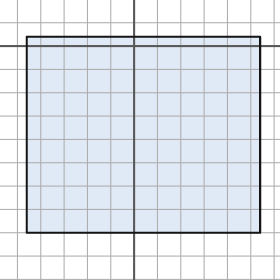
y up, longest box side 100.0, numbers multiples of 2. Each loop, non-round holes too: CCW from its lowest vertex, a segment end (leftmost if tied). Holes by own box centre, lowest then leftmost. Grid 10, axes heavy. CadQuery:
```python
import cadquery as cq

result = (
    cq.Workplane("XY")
    .moveTo(-46.0, -80.0)
    .lineTo(54.0, -80.0)
    .lineTo(54.0, 4.0)
    .lineTo(-46.0, 4.0)
    .close()
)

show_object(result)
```